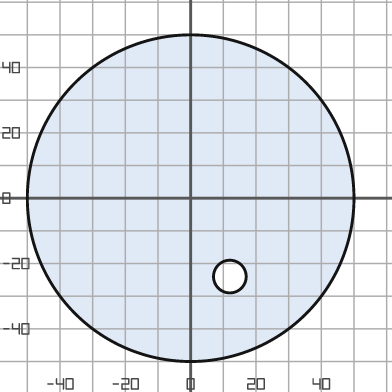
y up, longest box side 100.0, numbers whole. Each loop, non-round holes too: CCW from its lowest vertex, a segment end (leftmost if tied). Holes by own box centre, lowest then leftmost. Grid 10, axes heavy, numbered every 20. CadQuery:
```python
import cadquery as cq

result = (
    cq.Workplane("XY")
    .moveTo(0.0, 0.0)
    .circle(50.0)
    .moveTo(12.0, -24.0)
    .circle(5.0)
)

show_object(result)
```